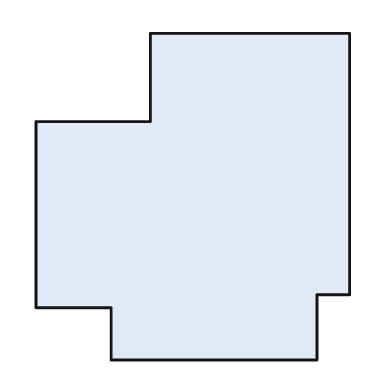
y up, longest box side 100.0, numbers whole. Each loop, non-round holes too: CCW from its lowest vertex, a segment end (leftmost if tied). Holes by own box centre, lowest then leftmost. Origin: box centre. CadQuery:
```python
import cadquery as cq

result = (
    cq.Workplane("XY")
    .moveTo(-25.0, -50.0)
    .lineTo(38.0, -50.0)
    .lineTo(38.0, -30.0)
    .lineTo(48.0, -30.0)
    .lineTo(48.0, 50.0)
    .lineTo(-13.0, 50.0)
    .lineTo(-13.0, 23.0)
    .lineTo(-48.0, 23.0)
    .lineTo(-48.0, -34.0)
    .lineTo(-25.0, -34.0)
    .close()
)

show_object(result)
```